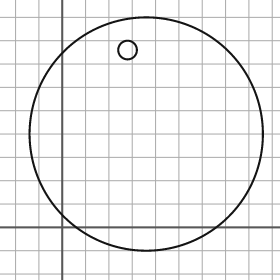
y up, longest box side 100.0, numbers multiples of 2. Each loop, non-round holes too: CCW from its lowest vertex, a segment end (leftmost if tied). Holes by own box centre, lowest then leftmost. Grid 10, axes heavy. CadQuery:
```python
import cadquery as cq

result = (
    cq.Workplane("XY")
    .moveTo(36.0, 40.0)
    .circle(50.0)
    .moveTo(28.0, 76.0)
    .circle(4.0)
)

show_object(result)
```